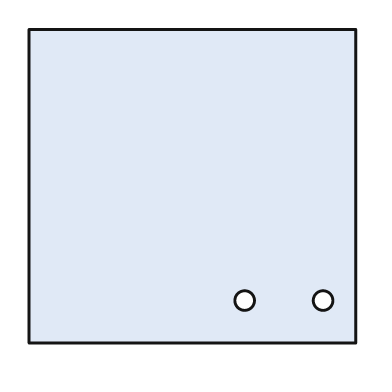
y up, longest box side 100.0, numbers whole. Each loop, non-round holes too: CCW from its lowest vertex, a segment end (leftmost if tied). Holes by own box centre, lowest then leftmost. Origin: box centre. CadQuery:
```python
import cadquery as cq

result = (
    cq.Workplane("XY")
    .moveTo(-50.0, -48.0)
    .lineTo(50.0, -48.0)
    .lineTo(50.0, 48.0)
    .lineTo(-50.0, 48.0)
    .close()
    .moveTo(16.0, -35.0)
    .circle(3.0)
    .moveTo(40.0, -35.0)
    .circle(3.0)
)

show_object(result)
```